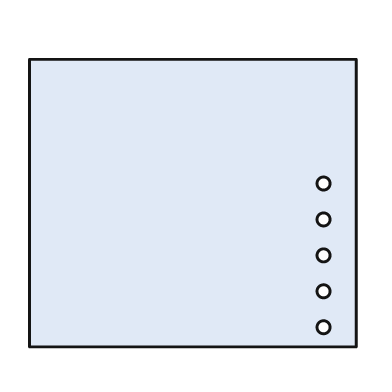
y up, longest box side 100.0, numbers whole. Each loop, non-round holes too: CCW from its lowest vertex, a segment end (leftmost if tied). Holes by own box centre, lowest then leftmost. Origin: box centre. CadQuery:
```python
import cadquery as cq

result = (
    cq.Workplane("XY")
    .moveTo(-50.0, -44.0)
    .lineTo(50.0, -44.0)
    .lineTo(50.0, 44.0)
    .lineTo(-50.0, 44.0)
    .close()
    .moveTo(40.0, -38.0)
    .circle(2.0)
    .moveTo(40.0, -27.0)
    .circle(2.0)
    .moveTo(40.0, -16.0)
    .circle(2.0)
    .moveTo(40.0, -5.0)
    .circle(2.0)
    .moveTo(40.0, 6.0)
    .circle(2.0)
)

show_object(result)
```